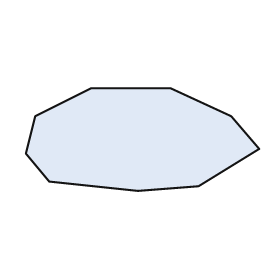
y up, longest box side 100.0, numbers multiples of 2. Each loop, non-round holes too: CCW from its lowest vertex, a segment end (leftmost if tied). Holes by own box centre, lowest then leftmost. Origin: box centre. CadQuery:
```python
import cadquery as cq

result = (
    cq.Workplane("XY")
    .moveTo(-2.0, -22.0)
    .lineTo(24.0, -20.0)
    .lineTo(50.0, -4.0)
    .lineTo(38.0, 10.0)
    .lineTo(12.0, 22.0)
    .lineTo(-22.0, 22.0)
    .lineTo(-46.0, 10.0)
    .lineTo(-50.0, -6.0)
    .lineTo(-40.0, -18.0)
    .close()
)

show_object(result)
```